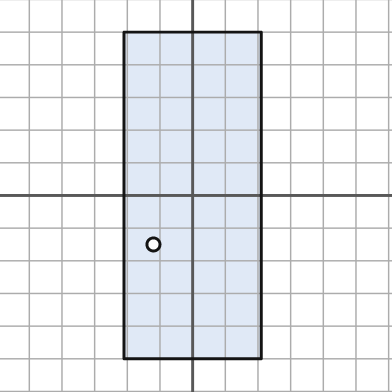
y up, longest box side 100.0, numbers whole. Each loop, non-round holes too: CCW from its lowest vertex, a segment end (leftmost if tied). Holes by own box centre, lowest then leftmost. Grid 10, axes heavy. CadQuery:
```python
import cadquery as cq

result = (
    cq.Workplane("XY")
    .moveTo(-21.0, -50.0)
    .lineTo(21.0, -50.0)
    .lineTo(21.0, 50.0)
    .lineTo(-21.0, 50.0)
    .close()
    .moveTo(-12.0, -15.0)
    .circle(2.0)
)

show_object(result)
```